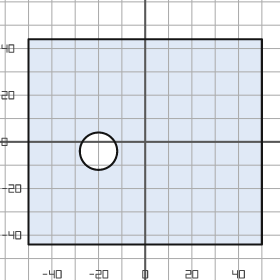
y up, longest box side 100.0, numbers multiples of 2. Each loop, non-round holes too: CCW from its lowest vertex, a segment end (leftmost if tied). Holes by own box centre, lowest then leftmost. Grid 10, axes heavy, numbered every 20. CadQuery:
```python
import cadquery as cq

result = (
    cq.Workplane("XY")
    .moveTo(-50.0, -44.0)
    .lineTo(50.0, -44.0)
    .lineTo(50.0, 44.0)
    .lineTo(-50.0, 44.0)
    .close()
    .moveTo(-20.0, -4.0)
    .circle(8.0)
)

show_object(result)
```